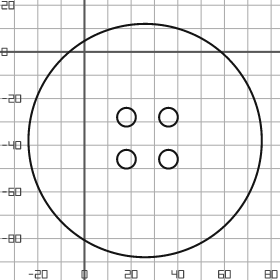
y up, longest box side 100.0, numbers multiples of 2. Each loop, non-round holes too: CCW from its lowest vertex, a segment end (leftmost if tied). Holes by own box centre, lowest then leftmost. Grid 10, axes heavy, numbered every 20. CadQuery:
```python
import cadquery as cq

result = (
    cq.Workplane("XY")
    .moveTo(26.0, -38.0)
    .circle(50.0)
    .moveTo(18.0, -46.0)
    .circle(4.0)
    .moveTo(36.0, -46.0)
    .circle(4.0)
    .moveTo(18.0, -28.0)
    .circle(4.0)
    .moveTo(36.0, -28.0)
    .circle(4.0)
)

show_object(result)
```